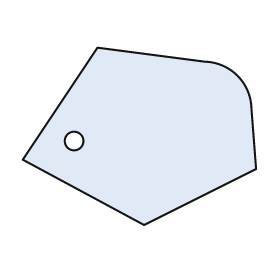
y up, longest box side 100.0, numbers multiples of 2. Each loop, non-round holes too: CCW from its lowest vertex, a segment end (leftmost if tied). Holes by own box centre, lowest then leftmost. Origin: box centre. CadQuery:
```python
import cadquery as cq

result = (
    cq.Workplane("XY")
    .moveTo(2.0, -38.0)
    .lineTo(50.0, -14.0)
    .lineTo(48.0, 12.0)
    .threePointArc((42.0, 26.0), (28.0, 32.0))
    .lineTo(-18.0, 38.0)
    .lineTo(-50.0, -10.0)
    .close()
    .moveTo(-28.0, -2.0)
    .circle(4.0)
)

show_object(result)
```